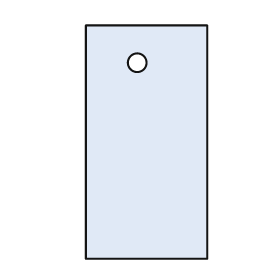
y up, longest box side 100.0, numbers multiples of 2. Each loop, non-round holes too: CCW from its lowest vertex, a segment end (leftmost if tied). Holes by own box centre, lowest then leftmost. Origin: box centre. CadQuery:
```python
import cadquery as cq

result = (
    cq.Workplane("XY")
    .moveTo(-26.0, -50.0)
    .lineTo(26.0, -50.0)
    .lineTo(26.0, 50.0)
    .lineTo(-26.0, 50.0)
    .close()
    .moveTo(-4.0, 34.0)
    .circle(4.0)
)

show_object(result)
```